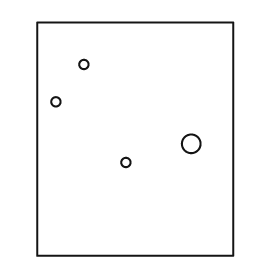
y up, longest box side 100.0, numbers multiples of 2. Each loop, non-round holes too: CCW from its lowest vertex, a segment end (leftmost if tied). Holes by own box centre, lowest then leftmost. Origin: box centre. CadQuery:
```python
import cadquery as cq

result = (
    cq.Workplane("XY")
    .moveTo(-42.0, -50.0)
    .lineTo(42.0, -50.0)
    .lineTo(42.0, 50.0)
    .lineTo(-42.0, 50.0)
    .close()
    .moveTo(-4.0, -10.0)
    .circle(2.0)
    .moveTo(24.0, -2.0)
    .circle(4.0)
    .moveTo(-34.0, 16.0)
    .circle(2.0)
    .moveTo(-22.0, 32.0)
    .circle(2.0)
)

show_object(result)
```